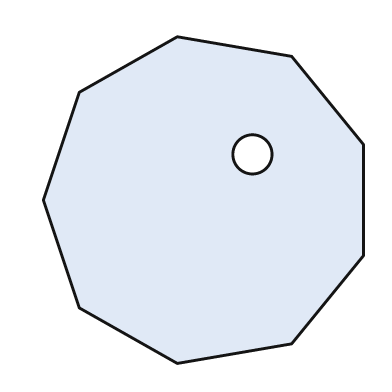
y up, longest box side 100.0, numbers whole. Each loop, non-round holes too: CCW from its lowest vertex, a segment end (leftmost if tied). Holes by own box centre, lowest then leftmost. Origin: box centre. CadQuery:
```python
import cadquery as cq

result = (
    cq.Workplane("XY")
    .moveTo(-8.0, -50.0)
    .lineTo(27.0, -44.0)
    .lineTo(49.0, -17.0)
    .lineTo(49.0, 17.0)
    .lineTo(27.0, 44.0)
    .lineTo(-8.0, 50.0)
    .lineTo(-38.0, 33.0)
    .lineTo(-49.0, 0.0)
    .lineTo(-38.0, -33.0)
    .close()
    .moveTo(15.0, 14.0)
    .circle(6.0)
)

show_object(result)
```